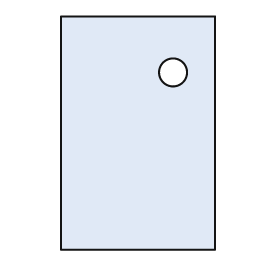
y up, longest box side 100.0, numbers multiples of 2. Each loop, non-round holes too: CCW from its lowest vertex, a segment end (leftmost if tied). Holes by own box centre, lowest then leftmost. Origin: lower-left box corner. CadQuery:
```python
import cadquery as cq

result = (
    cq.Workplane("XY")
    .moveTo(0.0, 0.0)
    .lineTo(66.0, 0.0)
    .lineTo(66.0, 100.0)
    .lineTo(0.0, 100.0)
    .close()
    .moveTo(48.0, 76.0)
    .circle(6.0)
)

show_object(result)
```